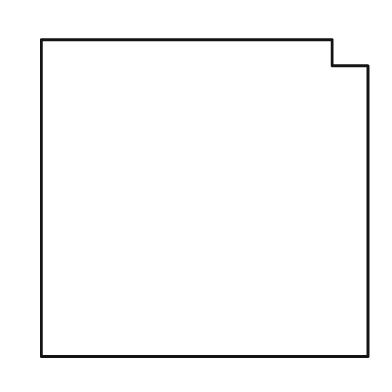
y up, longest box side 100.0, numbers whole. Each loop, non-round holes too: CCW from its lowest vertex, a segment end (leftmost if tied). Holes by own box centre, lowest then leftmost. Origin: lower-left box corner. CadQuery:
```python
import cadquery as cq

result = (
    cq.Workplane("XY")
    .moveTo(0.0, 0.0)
    .lineTo(100.0, 0.0)
    .lineTo(100.0, 89.0)
    .lineTo(89.0, 89.0)
    .lineTo(89.0, 97.0)
    .lineTo(0.0, 97.0)
    .close()
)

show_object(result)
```